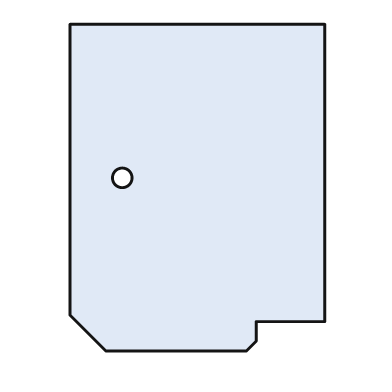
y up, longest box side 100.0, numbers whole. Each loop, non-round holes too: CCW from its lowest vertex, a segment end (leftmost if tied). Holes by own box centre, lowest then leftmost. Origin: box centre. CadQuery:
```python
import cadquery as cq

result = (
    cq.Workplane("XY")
    .moveTo(-28.0, -50.0)
    .lineTo(15.0, -50.0)
    .lineTo(18.0, -47.0)
    .lineTo(18.0, -41.0)
    .lineTo(39.0, -41.0)
    .lineTo(39.0, 50.0)
    .lineTo(-39.0, 50.0)
    .lineTo(-39.0, -39.0)
    .close()
    .moveTo(-23.0, 3.0)
    .circle(3.0)
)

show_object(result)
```